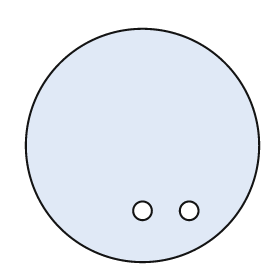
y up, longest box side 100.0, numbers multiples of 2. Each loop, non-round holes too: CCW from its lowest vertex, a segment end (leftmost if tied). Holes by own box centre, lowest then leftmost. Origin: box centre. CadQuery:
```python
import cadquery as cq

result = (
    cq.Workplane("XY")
    .moveTo(0.0, 0.0)
    .circle(50.0)
    .moveTo(0.0, -28.0)
    .circle(4.0)
    .moveTo(20.0, -28.0)
    .circle(4.0)
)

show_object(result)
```